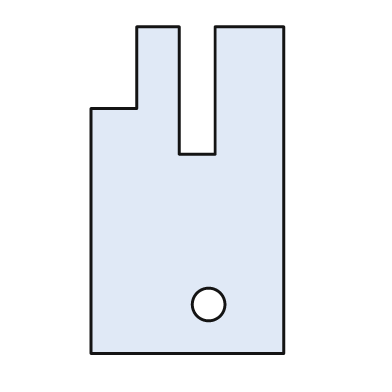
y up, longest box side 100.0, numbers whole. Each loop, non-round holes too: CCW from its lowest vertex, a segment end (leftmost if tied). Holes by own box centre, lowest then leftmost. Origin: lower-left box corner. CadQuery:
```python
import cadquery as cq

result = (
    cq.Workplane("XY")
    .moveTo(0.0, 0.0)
    .lineTo(59.0, 0.0)
    .lineTo(59.0, 100.0)
    .lineTo(38.0, 100.0)
    .lineTo(38.0, 61.0)
    .lineTo(27.0, 61.0)
    .lineTo(27.0, 100.0)
    .lineTo(14.0, 100.0)
    .lineTo(14.0, 75.0)
    .lineTo(0.0, 75.0)
    .close()
    .moveTo(36.0, 15.0)
    .circle(5.0)
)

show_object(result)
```